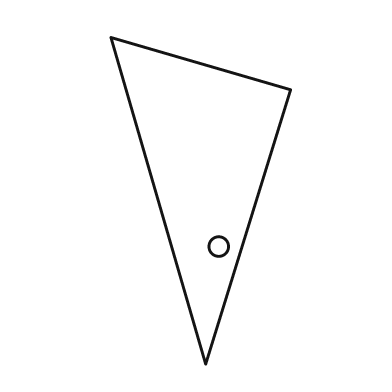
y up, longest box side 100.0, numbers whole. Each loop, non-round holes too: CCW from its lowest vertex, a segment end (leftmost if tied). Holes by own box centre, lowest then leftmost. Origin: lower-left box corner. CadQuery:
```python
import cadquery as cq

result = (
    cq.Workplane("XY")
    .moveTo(29.0, 0.0)
    .lineTo(55.0, 84.0)
    .lineTo(0.0, 100.0)
    .close()
    .moveTo(33.0, 36.0)
    .circle(3.0)
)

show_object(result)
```